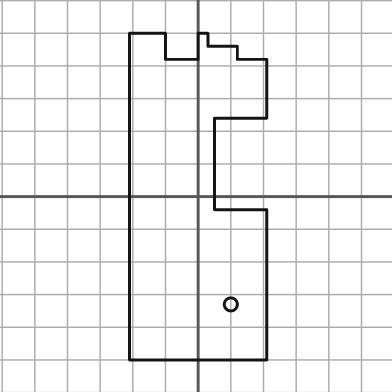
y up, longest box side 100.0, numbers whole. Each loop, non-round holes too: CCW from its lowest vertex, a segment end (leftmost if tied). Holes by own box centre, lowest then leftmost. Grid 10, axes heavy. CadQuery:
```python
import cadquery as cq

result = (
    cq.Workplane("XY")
    .moveTo(-21.0, -50.0)
    .lineTo(21.0, -50.0)
    .lineTo(21.0, -4.0)
    .lineTo(5.0, -4.0)
    .lineTo(5.0, 24.0)
    .lineTo(21.0, 24.0)
    .lineTo(21.0, 42.0)
    .lineTo(12.0, 42.0)
    .lineTo(12.0, 46.0)
    .lineTo(3.0, 46.0)
    .lineTo(3.0, 50.0)
    .lineTo(0.0, 50.0)
    .lineTo(0.0, 42.0)
    .lineTo(-10.0, 42.0)
    .lineTo(-10.0, 50.0)
    .lineTo(-21.0, 50.0)
    .close()
    .moveTo(10.0, -33.0)
    .circle(2.0)
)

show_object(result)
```